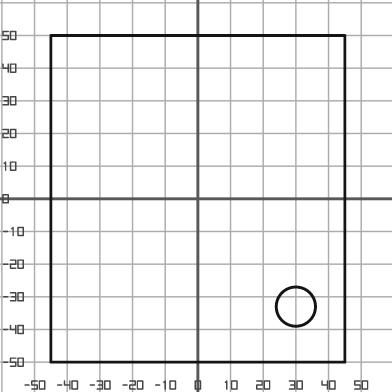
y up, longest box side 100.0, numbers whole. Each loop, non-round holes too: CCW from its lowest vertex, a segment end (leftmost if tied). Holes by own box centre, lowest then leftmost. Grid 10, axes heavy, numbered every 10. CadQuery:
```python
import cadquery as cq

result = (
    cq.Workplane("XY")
    .moveTo(-45.0, -50.0)
    .lineTo(45.0, -50.0)
    .lineTo(45.0, 50.0)
    .lineTo(-45.0, 50.0)
    .close()
    .moveTo(30.0, -33.0)
    .circle(6.0)
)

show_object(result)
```